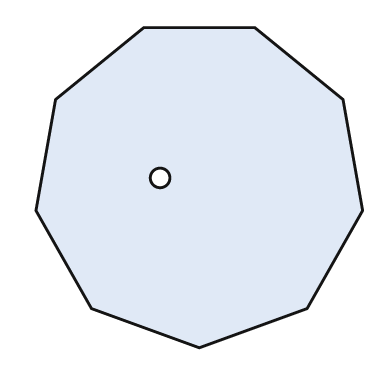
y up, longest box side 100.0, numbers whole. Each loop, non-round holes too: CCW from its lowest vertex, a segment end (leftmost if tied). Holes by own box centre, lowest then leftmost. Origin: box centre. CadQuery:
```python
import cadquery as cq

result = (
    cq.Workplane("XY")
    .moveTo(0.0, -49.0)
    .lineTo(33.0, -37.0)
    .lineTo(50.0, -7.0)
    .lineTo(44.0, 27.0)
    .lineTo(17.0, 49.0)
    .lineTo(-17.0, 49.0)
    .lineTo(-44.0, 27.0)
    .lineTo(-50.0, -7.0)
    .lineTo(-33.0, -37.0)
    .close()
    .moveTo(-12.0, 3.0)
    .circle(3.0)
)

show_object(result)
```